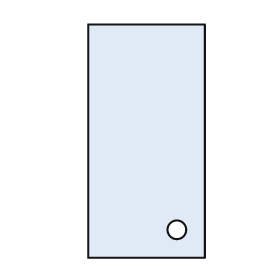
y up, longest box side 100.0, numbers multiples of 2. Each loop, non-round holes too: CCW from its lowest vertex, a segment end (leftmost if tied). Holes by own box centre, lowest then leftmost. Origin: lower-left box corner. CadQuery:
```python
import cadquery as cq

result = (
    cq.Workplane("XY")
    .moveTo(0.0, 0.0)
    .lineTo(50.0, 0.0)
    .lineTo(50.0, 100.0)
    .lineTo(0.0, 100.0)
    .close()
    .moveTo(38.0, 12.0)
    .circle(4.0)
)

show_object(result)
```